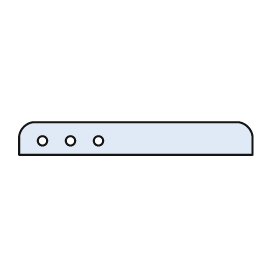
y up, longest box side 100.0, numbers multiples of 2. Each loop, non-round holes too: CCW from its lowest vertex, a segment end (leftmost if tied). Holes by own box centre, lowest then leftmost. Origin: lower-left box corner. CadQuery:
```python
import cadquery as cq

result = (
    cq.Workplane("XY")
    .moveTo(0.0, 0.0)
    .lineTo(100.0, 0.0)
    .lineTo(100.0, 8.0)
    .threePointArc((98.0, 12.0), (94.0, 14.0))
    .lineTo(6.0, 14.0)
    .threePointArc((2.0, 12.0), (0.0, 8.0))
    .close()
    .moveTo(10.0, 6.0)
    .circle(2.0)
    .moveTo(22.0, 6.0)
    .circle(2.0)
    .moveTo(34.0, 6.0)
    .circle(2.0)
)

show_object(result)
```